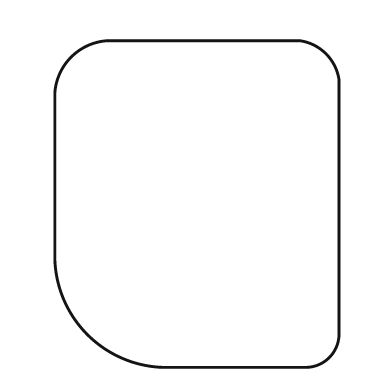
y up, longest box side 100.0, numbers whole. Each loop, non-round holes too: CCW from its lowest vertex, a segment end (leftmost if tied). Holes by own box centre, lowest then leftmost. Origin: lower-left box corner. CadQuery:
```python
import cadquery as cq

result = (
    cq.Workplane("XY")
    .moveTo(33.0, 0.0)
    .lineTo(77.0, 0.0)
    .threePointArc((84.0, 3.0), (87.0, 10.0))
    .lineTo(87.0, 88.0)
    .threePointArc((83.0, 96.0), (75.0, 100.0))
    .lineTo(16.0, 100.0)
    .threePointArc((5.0, 95.0), (0.0, 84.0))
    .lineTo(0.0, 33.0)
    .threePointArc((10.0, 10.0), (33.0, 0.0))
    .close()
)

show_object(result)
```